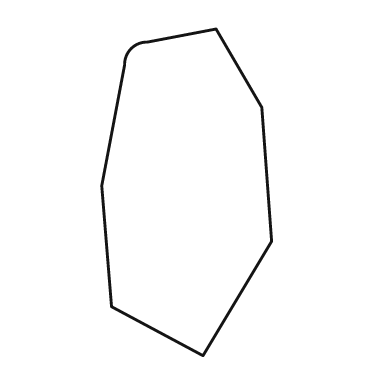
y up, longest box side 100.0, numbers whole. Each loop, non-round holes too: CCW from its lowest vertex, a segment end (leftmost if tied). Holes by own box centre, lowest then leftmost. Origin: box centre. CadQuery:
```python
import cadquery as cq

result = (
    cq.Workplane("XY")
    .moveTo(5.0, -50.0)
    .lineTo(26.0, -15.0)
    .lineTo(23.0, 26.0)
    .lineTo(9.0, 50.0)
    .lineTo(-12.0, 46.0)
    .threePointArc((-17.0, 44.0), (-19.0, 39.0))
    .lineTo(-26.0, 2.0)
    .lineTo(-23.0, -35.0)
    .close()
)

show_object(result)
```